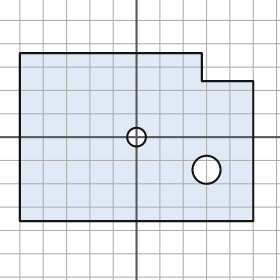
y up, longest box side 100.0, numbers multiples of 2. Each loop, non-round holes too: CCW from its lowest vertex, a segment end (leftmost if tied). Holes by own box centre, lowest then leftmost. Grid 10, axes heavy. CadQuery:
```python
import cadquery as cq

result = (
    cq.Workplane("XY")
    .moveTo(-50.0, -36.0)
    .lineTo(50.0, -36.0)
    .lineTo(50.0, 24.0)
    .lineTo(28.0, 24.0)
    .lineTo(28.0, 36.0)
    .lineTo(-50.0, 36.0)
    .close()
    .moveTo(30.0, -14.0)
    .circle(6.0)
    .moveTo(0.0, 0.0)
    .circle(4.0)
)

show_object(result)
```